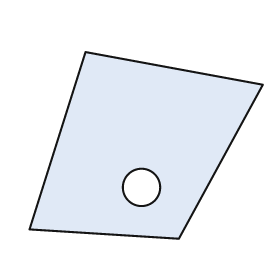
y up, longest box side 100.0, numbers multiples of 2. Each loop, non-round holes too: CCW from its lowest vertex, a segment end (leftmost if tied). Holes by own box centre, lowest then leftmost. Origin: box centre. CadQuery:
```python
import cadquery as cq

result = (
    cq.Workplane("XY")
    .moveTo(14.0, -40.0)
    .lineTo(50.0, 26.0)
    .lineTo(-26.0, 40.0)
    .lineTo(-50.0, -36.0)
    .close()
    .moveTo(-2.0, -18.0)
    .circle(8.0)
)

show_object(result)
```